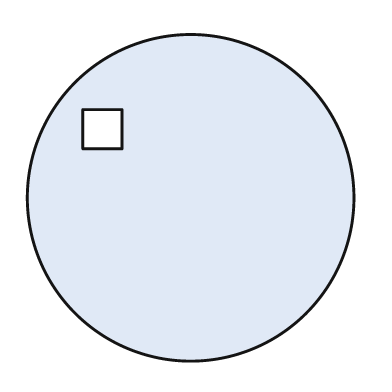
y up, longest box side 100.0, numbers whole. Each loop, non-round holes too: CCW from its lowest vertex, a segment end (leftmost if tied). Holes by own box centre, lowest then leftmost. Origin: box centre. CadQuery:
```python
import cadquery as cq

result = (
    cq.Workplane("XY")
    .moveTo(0.0, 0.0)
    .circle(50.0)
    .moveTo(-33.0, 15.0)
    .lineTo(-21.0, 15.0)
    .lineTo(-21.0, 27.0)
    .lineTo(-33.0, 27.0)
    .close()
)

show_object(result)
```